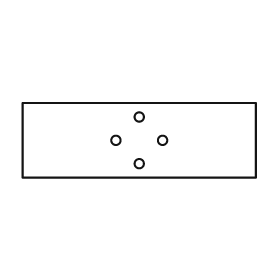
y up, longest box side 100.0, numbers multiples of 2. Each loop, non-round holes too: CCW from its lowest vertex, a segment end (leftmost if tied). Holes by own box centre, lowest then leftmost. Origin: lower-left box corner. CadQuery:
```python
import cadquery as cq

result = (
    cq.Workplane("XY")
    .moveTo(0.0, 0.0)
    .lineTo(100.0, 0.0)
    .lineTo(100.0, 32.0)
    .lineTo(0.0, 32.0)
    .close()
    .moveTo(50.0, 6.0)
    .circle(2.0)
    .moveTo(40.0, 16.0)
    .circle(2.0)
    .moveTo(60.0, 16.0)
    .circle(2.0)
    .moveTo(50.0, 26.0)
    .circle(2.0)
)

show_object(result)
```